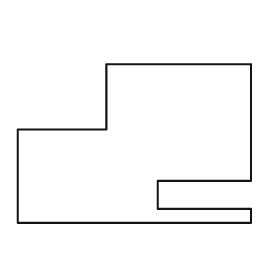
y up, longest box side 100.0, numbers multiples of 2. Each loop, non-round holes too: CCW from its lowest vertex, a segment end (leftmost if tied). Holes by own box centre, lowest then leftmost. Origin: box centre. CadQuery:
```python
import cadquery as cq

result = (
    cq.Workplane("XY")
    .moveTo(-50.0, -34.0)
    .lineTo(50.0, -34.0)
    .lineTo(50.0, -28.0)
    .lineTo(10.0, -28.0)
    .lineTo(10.0, -16.0)
    .lineTo(50.0, -16.0)
    .lineTo(50.0, 34.0)
    .lineTo(-12.0, 34.0)
    .lineTo(-12.0, 6.0)
    .lineTo(-50.0, 6.0)
    .close()
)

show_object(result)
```